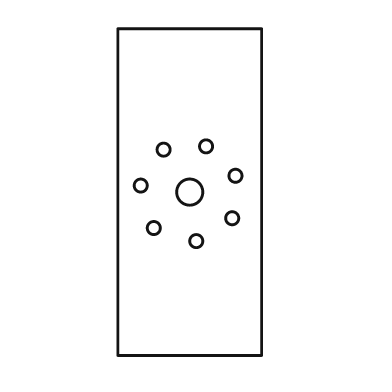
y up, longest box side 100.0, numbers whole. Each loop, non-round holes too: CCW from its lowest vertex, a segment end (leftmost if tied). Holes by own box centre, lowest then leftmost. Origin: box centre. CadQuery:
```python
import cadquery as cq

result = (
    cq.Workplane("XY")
    .moveTo(-22.0, -50.0)
    .lineTo(22.0, -50.0)
    .lineTo(22.0, 50.0)
    .lineTo(-22.0, 50.0)
    .close()
    .moveTo(2.0, -15.0)
    .circle(2.0)
    .moveTo(-11.0, -11.0)
    .circle(2.0)
    .moveTo(13.0, -8.0)
    .circle(2.0)
    .moveTo(0.0, 0.0)
    .circle(4.0)
    .moveTo(-15.0, 2.0)
    .circle(2.0)
    .moveTo(14.0, 5.0)
    .circle(2.0)
    .moveTo(-8.0, 13.0)
    .circle(2.0)
    .moveTo(5.0, 14.0)
    .circle(2.0)
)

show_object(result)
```